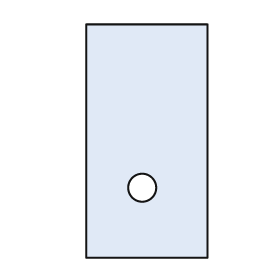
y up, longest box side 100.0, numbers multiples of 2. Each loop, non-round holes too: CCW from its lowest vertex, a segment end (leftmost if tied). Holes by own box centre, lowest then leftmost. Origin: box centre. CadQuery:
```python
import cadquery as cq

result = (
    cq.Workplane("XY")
    .moveTo(-26.0, -50.0)
    .lineTo(26.0, -50.0)
    .lineTo(26.0, 50.0)
    .lineTo(-26.0, 50.0)
    .close()
    .moveTo(-2.0, -20.0)
    .circle(6.0)
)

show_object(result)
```